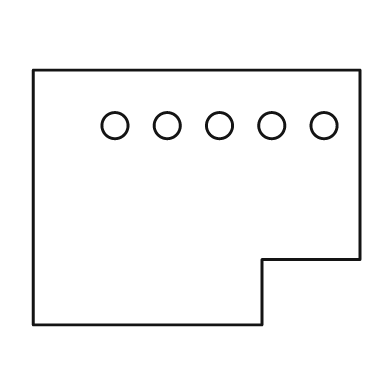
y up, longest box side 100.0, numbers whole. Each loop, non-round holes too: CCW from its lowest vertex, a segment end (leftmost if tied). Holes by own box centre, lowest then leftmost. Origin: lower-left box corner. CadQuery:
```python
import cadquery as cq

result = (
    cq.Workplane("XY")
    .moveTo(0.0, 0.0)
    .lineTo(70.0, 0.0)
    .lineTo(70.0, 20.0)
    .lineTo(100.0, 20.0)
    .lineTo(100.0, 78.0)
    .lineTo(0.0, 78.0)
    .close()
    .moveTo(25.0, 61.0)
    .circle(4.0)
    .moveTo(41.0, 61.0)
    .circle(4.0)
    .moveTo(57.0, 61.0)
    .circle(4.0)
    .moveTo(73.0, 61.0)
    .circle(4.0)
    .moveTo(89.0, 61.0)
    .circle(4.0)
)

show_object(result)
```